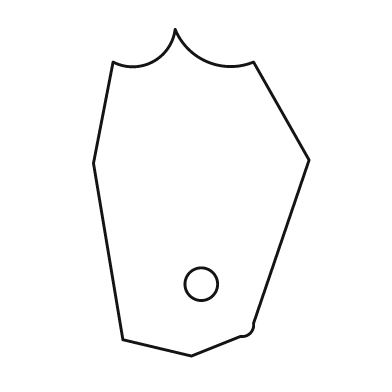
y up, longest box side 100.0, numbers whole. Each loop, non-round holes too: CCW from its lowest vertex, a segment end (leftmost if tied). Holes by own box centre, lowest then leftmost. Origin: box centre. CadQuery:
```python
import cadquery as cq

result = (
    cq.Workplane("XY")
    .moveTo(-3.0, -50.0)
    .lineTo(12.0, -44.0)
    .threePointArc((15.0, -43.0), (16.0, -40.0))
    .lineTo(33.0, 10.0)
    .lineTo(16.0, 40.0)
    .threePointArc((2.0, 40.0), (-8.0, 50.0))
    .threePointArc((-15.0, 40.0), (-27.0, 40.0))
    .lineTo(-33.0, 9.0)
    .lineTo(-24.0, -45.0)
    .close()
    .moveTo(0.0, -28.0)
    .circle(5.0)
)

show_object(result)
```